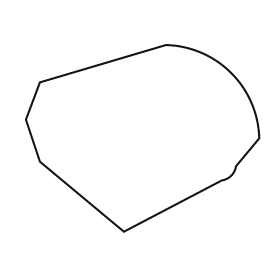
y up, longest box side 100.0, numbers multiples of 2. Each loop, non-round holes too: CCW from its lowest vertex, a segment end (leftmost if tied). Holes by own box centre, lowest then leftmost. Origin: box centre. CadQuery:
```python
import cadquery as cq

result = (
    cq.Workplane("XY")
    .moveTo(-8.0, -40.0)
    .lineTo(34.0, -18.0)
    .threePointArc((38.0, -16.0), (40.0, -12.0))
    .lineTo(50.0, 0.0)
    .threePointArc((38.0, 28.0), (10.0, 40.0))
    .lineTo(-44.0, 24.0)
    .lineTo(-50.0, 8.0)
    .lineTo(-44.0, -10.0)
    .close()
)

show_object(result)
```